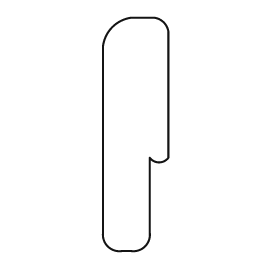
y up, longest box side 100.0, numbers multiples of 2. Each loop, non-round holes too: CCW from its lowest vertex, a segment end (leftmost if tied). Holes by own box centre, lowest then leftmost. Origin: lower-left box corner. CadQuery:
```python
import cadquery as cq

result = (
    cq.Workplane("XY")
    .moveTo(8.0, 0.0)
    .lineTo(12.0, 0.0)
    .threePointArc((18.0, 2.0), (20.0, 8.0))
    .lineTo(20.0, 40.0)
    .threePointArc((24.0, 38.0), (28.0, 40.0))
    .lineTo(28.0, 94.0)
    .threePointArc((26.0, 98.0), (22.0, 100.0))
    .lineTo(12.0, 100.0)
    .threePointArc((4.0, 96.0), (0.0, 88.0))
    .lineTo(0.0, 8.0)
    .threePointArc((2.0, 2.0), (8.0, 0.0))
    .close()
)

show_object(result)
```